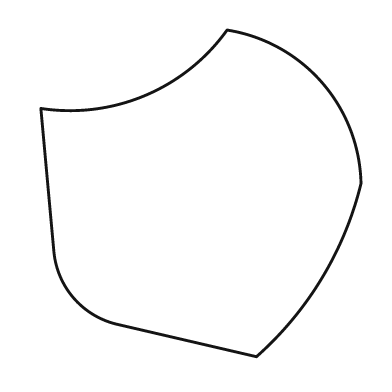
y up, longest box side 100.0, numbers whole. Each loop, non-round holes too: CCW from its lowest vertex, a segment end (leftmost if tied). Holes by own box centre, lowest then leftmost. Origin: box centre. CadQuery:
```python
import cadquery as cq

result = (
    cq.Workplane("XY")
    .moveTo(17.0, -50.0)
    .threePointArc((37.0, -26.0), (49.0, 3.0))
    .threePointArc((37.0, 34.0), (8.0, 50.0))
    .threePointArc((-17.0, 30.0), (-49.0, 26.0))
    .lineTo(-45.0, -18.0)
    .threePointArc((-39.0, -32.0), (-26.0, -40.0))
    .close()
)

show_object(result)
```